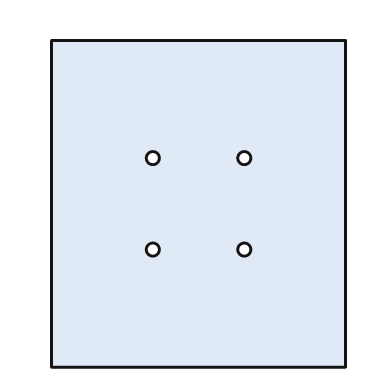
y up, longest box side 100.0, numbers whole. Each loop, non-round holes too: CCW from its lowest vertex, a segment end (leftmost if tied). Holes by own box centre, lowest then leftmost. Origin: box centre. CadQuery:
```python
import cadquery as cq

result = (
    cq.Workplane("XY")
    .moveTo(-45.0, -50.0)
    .lineTo(45.0, -50.0)
    .lineTo(45.0, 50.0)
    .lineTo(-45.0, 50.0)
    .close()
    .moveTo(-14.0, -14.0)
    .circle(2.0)
    .moveTo(14.0, -14.0)
    .circle(2.0)
    .moveTo(-14.0, 14.0)
    .circle(2.0)
    .moveTo(14.0, 14.0)
    .circle(2.0)
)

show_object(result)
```